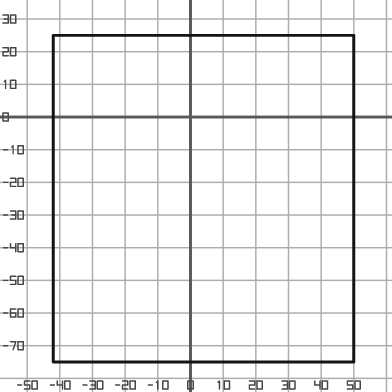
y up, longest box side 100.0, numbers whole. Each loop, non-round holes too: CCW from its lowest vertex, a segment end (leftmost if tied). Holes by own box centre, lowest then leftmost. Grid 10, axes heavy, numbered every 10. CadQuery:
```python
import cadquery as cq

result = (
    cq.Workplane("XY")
    .moveTo(-42.0, -75.0)
    .lineTo(50.0, -75.0)
    .lineTo(50.0, 25.0)
    .lineTo(-42.0, 25.0)
    .close()
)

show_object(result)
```